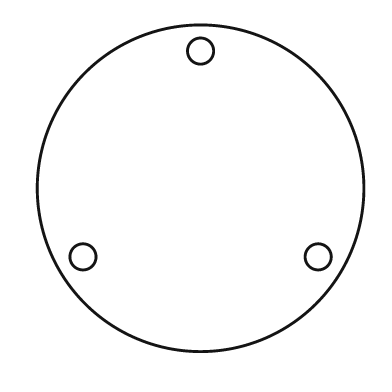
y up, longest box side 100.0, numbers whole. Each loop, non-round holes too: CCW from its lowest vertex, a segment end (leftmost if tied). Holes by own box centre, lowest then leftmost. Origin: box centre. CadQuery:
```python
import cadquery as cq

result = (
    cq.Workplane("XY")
    .moveTo(0.0, 0.0)
    .circle(50.0)
    .moveTo(-36.0, -21.0)
    .circle(4.0)
    .moveTo(36.0, -21.0)
    .circle(4.0)
    .moveTo(0.0, 42.0)
    .circle(4.0)
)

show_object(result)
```